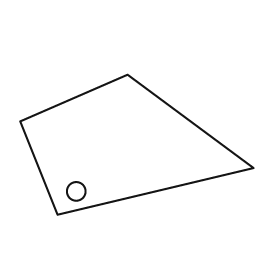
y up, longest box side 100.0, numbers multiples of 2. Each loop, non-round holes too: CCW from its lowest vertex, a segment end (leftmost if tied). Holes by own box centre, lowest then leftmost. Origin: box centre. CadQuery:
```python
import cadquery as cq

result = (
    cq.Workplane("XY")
    .moveTo(-34.0, -30.0)
    .lineTo(50.0, -10.0)
    .lineTo(-4.0, 30.0)
    .lineTo(-50.0, 10.0)
    .close()
    .moveTo(-26.0, -20.0)
    .circle(4.0)
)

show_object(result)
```